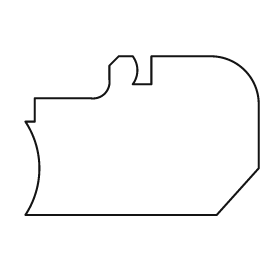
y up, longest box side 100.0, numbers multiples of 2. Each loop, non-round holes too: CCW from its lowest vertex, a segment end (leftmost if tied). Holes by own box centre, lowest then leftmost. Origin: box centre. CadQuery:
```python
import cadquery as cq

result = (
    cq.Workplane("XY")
    .moveTo(-50.0, -34.0)
    .lineTo(32.0, -34.0)
    .lineTo(50.0, -14.0)
    .lineTo(50.0, 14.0)
    .threePointArc((44.0, 28.0), (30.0, 34.0))
    .lineTo(4.0, 34.0)
    .lineTo(4.0, 22.0)
    .lineTo(-4.0, 22.0)
    .threePointArc((-2.0, 28.0), (-4.0, 34.0))
    .lineTo(-10.0, 34.0)
    .lineTo(-14.0, 30.0)
    .lineTo(-14.0, 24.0)
    .threePointArc((-16.0, 18.0), (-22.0, 16.0))
    .lineTo(-46.0, 16.0)
    .lineTo(-46.0, 6.0)
    .lineTo(-50.0, 6.0)
    .threePointArc((-44.0, -14.0), (-50.0, -34.0))
    .close()
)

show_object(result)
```